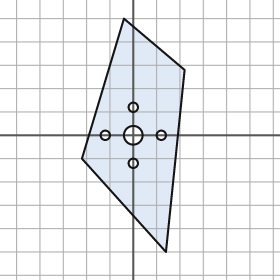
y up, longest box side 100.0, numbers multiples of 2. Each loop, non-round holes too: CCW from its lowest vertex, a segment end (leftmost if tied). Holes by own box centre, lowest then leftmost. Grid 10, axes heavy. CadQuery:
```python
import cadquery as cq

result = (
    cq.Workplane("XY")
    .moveTo(14.0, -50.0)
    .lineTo(22.0, 28.0)
    .lineTo(-4.0, 50.0)
    .lineTo(-22.0, -10.0)
    .close()
    .moveTo(0.0, -12.0)
    .circle(2.0)
    .moveTo(-12.0, 0.0)
    .circle(2.0)
    .moveTo(0.0, 0.0)
    .circle(4.0)
    .moveTo(12.0, 0.0)
    .circle(2.0)
    .moveTo(0.0, 12.0)
    .circle(2.0)
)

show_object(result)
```